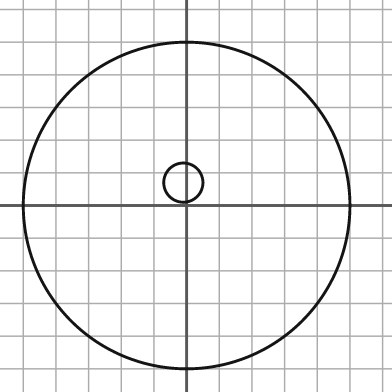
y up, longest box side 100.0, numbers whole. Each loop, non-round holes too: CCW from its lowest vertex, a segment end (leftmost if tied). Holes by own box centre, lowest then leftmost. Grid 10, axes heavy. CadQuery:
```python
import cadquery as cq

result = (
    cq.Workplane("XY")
    .moveTo(0.0, 0.0)
    .circle(50.0)
    .moveTo(-1.0, 7.0)
    .circle(6.0)
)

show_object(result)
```